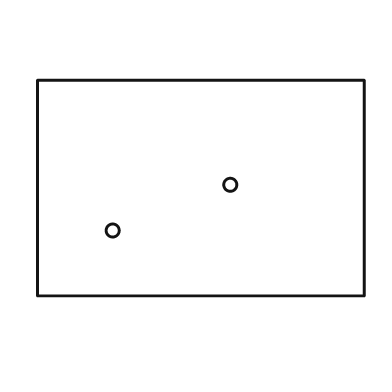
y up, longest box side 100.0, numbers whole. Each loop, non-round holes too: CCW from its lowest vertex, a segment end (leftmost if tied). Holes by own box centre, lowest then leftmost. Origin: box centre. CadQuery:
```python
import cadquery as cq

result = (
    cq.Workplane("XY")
    .moveTo(-50.0, -33.0)
    .lineTo(50.0, -33.0)
    .lineTo(50.0, 33.0)
    .lineTo(-50.0, 33.0)
    .close()
    .moveTo(-27.0, -13.0)
    .circle(2.0)
    .moveTo(9.0, 1.0)
    .circle(2.0)
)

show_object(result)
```